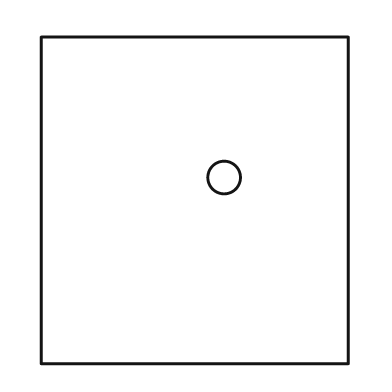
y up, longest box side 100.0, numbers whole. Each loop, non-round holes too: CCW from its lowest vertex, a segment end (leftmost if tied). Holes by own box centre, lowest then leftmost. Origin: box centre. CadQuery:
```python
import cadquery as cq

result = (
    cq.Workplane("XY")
    .moveTo(-47.0, -50.0)
    .lineTo(47.0, -50.0)
    .lineTo(47.0, 50.0)
    .lineTo(-47.0, 50.0)
    .close()
    .moveTo(9.0, 7.0)
    .circle(5.0)
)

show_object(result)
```